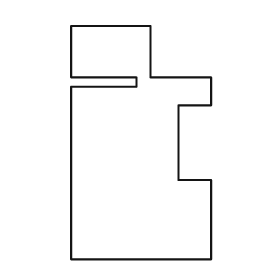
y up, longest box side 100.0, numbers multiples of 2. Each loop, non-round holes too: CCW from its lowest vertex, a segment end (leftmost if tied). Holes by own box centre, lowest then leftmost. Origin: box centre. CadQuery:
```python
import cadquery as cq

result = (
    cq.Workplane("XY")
    .moveTo(-30.0, -50.0)
    .lineTo(30.0, -50.0)
    .lineTo(30.0, -16.0)
    .lineTo(16.0, -16.0)
    .lineTo(16.0, 16.0)
    .lineTo(30.0, 16.0)
    .lineTo(30.0, 28.0)
    .lineTo(4.0, 28.0)
    .lineTo(4.0, 50.0)
    .lineTo(-30.0, 50.0)
    .lineTo(-30.0, 28.0)
    .lineTo(-2.0, 28.0)
    .lineTo(-2.0, 24.0)
    .lineTo(-30.0, 24.0)
    .close()
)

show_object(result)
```